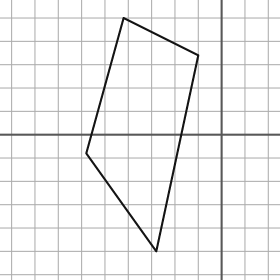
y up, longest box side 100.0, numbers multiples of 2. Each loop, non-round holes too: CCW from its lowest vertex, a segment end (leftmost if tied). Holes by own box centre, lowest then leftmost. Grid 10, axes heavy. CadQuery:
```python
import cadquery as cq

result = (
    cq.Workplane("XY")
    .moveTo(-28.0, -50.0)
    .lineTo(-10.0, 34.0)
    .lineTo(-42.0, 50.0)
    .lineTo(-58.0, -8.0)
    .close()
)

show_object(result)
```